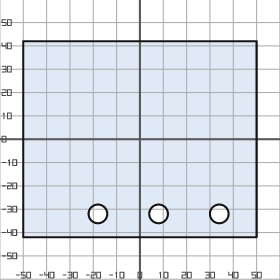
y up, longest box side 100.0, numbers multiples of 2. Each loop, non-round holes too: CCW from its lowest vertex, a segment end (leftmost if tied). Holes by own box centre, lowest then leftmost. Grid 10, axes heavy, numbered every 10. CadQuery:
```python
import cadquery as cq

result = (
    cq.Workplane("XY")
    .moveTo(-50.0, -42.0)
    .lineTo(50.0, -42.0)
    .lineTo(50.0, 42.0)
    .lineTo(-50.0, 42.0)
    .close()
    .moveTo(-18.0, -32.0)
    .circle(4.0)
    .moveTo(8.0, -32.0)
    .circle(4.0)
    .moveTo(34.0, -32.0)
    .circle(4.0)
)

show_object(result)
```